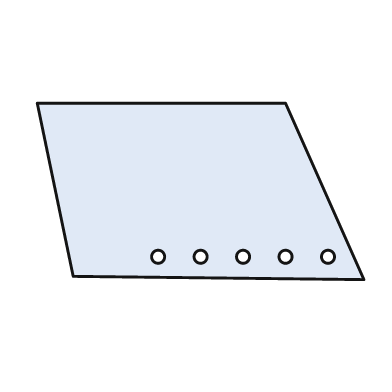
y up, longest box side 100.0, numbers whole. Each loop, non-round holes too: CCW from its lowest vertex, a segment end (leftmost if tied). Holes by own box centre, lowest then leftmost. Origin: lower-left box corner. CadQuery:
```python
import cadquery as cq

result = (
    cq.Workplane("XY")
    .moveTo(100.0, 0.0)
    .lineTo(76.0, 54.0)
    .lineTo(0.0, 54.0)
    .lineTo(11.0, 1.0)
    .close()
    .moveTo(37.0, 7.0)
    .circle(2.0)
    .moveTo(50.0, 7.0)
    .circle(2.0)
    .moveTo(63.0, 7.0)
    .circle(2.0)
    .moveTo(76.0, 7.0)
    .circle(2.0)
    .moveTo(89.0, 7.0)
    .circle(2.0)
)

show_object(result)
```